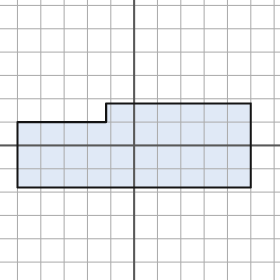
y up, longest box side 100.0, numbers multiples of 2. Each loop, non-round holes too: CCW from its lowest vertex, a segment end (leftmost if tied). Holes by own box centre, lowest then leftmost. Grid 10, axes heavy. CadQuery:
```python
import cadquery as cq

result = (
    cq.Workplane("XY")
    .moveTo(-50.0, -18.0)
    .lineTo(50.0, -18.0)
    .lineTo(50.0, 18.0)
    .lineTo(-12.0, 18.0)
    .lineTo(-12.0, 10.0)
    .lineTo(-50.0, 10.0)
    .close()
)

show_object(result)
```